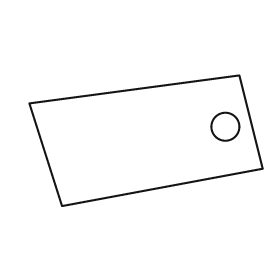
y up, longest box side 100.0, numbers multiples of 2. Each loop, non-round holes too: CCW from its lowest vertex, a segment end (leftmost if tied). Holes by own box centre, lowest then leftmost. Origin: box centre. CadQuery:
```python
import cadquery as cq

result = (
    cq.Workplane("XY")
    .moveTo(-36.0, -28.0)
    .lineTo(50.0, -12.0)
    .lineTo(40.0, 28.0)
    .lineTo(-50.0, 16.0)
    .close()
    .moveTo(34.0, 6.0)
    .circle(6.0)
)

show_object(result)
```